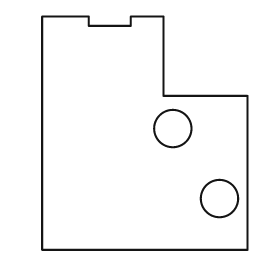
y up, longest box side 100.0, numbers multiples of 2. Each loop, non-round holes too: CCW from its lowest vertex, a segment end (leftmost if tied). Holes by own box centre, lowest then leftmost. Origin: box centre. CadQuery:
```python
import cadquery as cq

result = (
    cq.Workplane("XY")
    .moveTo(-44.0, -50.0)
    .lineTo(44.0, -50.0)
    .lineTo(44.0, 16.0)
    .lineTo(8.0, 16.0)
    .lineTo(8.0, 50.0)
    .lineTo(-6.0, 50.0)
    .lineTo(-6.0, 46.0)
    .lineTo(-24.0, 46.0)
    .lineTo(-24.0, 50.0)
    .lineTo(-44.0, 50.0)
    .close()
    .moveTo(32.0, -28.0)
    .circle(8.0)
    .moveTo(12.0, 2.0)
    .circle(8.0)
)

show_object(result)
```